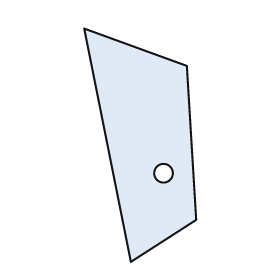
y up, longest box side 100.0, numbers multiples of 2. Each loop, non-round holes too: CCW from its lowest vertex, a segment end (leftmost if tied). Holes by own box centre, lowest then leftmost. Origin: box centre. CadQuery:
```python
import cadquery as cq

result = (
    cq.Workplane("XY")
    .moveTo(-4.0, -50.0)
    .lineTo(24.0, -32.0)
    .lineTo(20.0, 34.0)
    .lineTo(-24.0, 50.0)
    .close()
    .moveTo(10.0, -12.0)
    .circle(4.0)
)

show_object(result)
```